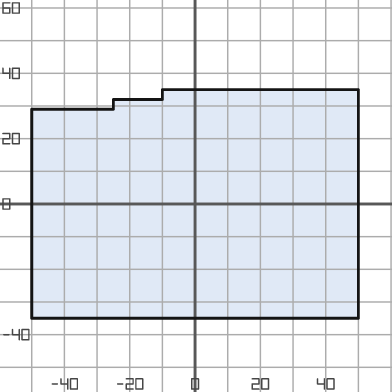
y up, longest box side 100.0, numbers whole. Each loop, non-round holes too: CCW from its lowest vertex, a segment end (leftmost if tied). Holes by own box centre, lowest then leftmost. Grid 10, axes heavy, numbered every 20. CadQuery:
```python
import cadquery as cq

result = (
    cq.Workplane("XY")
    .moveTo(-50.0, -35.0)
    .lineTo(50.0, -35.0)
    .lineTo(50.0, 35.0)
    .lineTo(-10.0, 35.0)
    .lineTo(-10.0, 32.0)
    .lineTo(-25.0, 32.0)
    .lineTo(-25.0, 29.0)
    .lineTo(-50.0, 29.0)
    .close()
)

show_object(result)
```